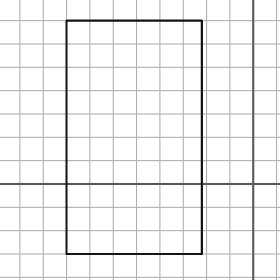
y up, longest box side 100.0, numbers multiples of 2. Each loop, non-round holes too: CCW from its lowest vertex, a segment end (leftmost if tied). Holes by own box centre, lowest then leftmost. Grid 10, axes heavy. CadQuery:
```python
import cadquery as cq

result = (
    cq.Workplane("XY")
    .moveTo(-80.0, -30.0)
    .lineTo(-22.0, -30.0)
    .lineTo(-22.0, 70.0)
    .lineTo(-80.0, 70.0)
    .close()
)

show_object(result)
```